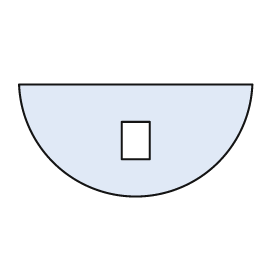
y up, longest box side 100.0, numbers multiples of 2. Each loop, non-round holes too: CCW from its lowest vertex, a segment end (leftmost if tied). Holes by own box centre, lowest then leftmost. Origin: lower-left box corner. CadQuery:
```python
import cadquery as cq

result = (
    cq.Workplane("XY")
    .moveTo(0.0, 48.0)
    .threePointArc((50.0, 0.0), (100.0, 48.0))
    .close()
    .moveTo(44.0, 16.0)
    .lineTo(56.0, 16.0)
    .lineTo(56.0, 32.0)
    .lineTo(44.0, 32.0)
    .close()
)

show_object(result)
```